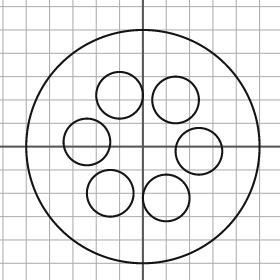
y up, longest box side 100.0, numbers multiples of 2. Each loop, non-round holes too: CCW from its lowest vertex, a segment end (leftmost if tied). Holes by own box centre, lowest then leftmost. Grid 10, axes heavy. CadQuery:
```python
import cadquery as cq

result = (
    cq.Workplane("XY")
    .moveTo(0.0, 0.0)
    .circle(50.0)
    .moveTo(10.0, -22.0)
    .circle(10.0)
    .moveTo(-14.0, -20.0)
    .circle(10.0)
    .moveTo(24.0, -2.0)
    .circle(10.0)
    .moveTo(-24.0, 2.0)
    .circle(10.0)
    .moveTo(14.0, 20.0)
    .circle(10.0)
    .moveTo(-10.0, 22.0)
    .circle(10.0)
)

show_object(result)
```